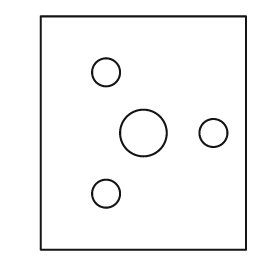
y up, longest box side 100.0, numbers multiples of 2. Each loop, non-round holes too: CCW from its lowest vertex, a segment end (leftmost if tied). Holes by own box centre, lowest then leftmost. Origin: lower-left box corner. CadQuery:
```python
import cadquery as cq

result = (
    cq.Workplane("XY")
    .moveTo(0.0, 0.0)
    .lineTo(88.0, 0.0)
    .lineTo(88.0, 100.0)
    .lineTo(0.0, 100.0)
    .close()
    .moveTo(28.0, 24.0)
    .circle(6.0)
    .moveTo(44.0, 50.0)
    .circle(10.0)
    .moveTo(74.0, 50.0)
    .circle(6.0)
    .moveTo(28.0, 76.0)
    .circle(6.0)
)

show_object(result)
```